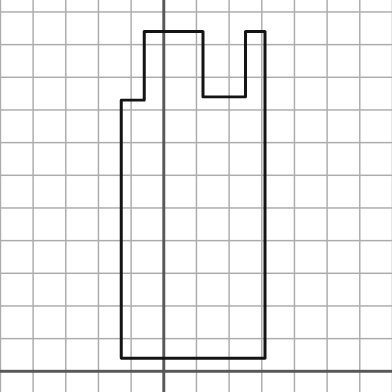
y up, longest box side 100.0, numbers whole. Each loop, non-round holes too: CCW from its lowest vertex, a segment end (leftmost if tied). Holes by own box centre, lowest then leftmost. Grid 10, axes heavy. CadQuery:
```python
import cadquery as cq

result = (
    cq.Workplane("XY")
    .moveTo(-13.0, 4.0)
    .lineTo(31.0, 4.0)
    .lineTo(31.0, 104.0)
    .lineTo(25.0, 104.0)
    .lineTo(25.0, 84.0)
    .lineTo(12.0, 84.0)
    .lineTo(12.0, 104.0)
    .lineTo(-6.0, 104.0)
    .lineTo(-6.0, 83.0)
    .lineTo(-13.0, 83.0)
    .close()
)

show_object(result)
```